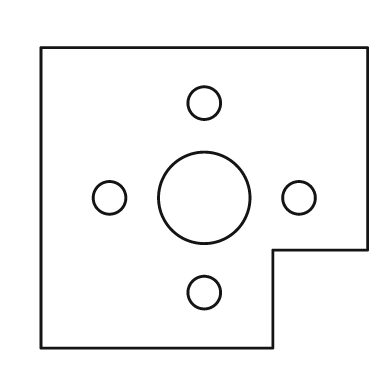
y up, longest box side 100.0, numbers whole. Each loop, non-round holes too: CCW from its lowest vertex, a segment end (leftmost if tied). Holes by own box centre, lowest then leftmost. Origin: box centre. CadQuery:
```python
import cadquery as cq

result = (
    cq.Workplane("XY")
    .moveTo(-50.0, -46.0)
    .lineTo(21.0, -46.0)
    .lineTo(21.0, -16.0)
    .lineTo(50.0, -16.0)
    .lineTo(50.0, 46.0)
    .lineTo(-50.0, 46.0)
    .close()
    .moveTo(0.0, -29.0)
    .circle(5.0)
    .moveTo(-29.0, 0.0)
    .circle(5.0)
    .moveTo(0.0, 0.0)
    .circle(14.0)
    .moveTo(29.0, 0.0)
    .circle(5.0)
    .moveTo(0.0, 29.0)
    .circle(5.0)
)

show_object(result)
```